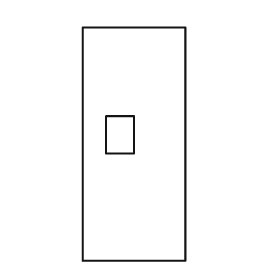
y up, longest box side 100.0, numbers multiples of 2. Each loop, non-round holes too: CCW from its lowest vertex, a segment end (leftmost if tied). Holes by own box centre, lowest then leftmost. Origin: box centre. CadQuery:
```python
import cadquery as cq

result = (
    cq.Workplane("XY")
    .moveTo(-22.0, -50.0)
    .lineTo(22.0, -50.0)
    .lineTo(22.0, 50.0)
    .lineTo(-22.0, 50.0)
    .close()
    .moveTo(-12.0, -4.0)
    .lineTo(0.0, -4.0)
    .lineTo(0.0, 12.0)
    .lineTo(-12.0, 12.0)
    .close()
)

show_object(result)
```